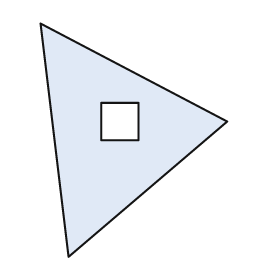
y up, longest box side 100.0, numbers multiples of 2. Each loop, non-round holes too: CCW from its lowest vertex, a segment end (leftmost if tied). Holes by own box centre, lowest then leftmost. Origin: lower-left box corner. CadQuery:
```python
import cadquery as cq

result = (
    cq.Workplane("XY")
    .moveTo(12.0, 0.0)
    .lineTo(80.0, 58.0)
    .lineTo(0.0, 100.0)
    .close()
    .moveTo(26.0, 50.0)
    .lineTo(42.0, 50.0)
    .lineTo(42.0, 66.0)
    .lineTo(26.0, 66.0)
    .close()
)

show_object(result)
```